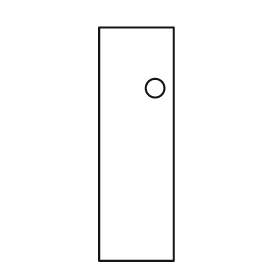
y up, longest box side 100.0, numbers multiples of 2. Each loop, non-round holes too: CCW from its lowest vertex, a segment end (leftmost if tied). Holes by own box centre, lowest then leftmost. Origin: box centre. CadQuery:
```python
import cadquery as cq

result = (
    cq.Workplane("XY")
    .moveTo(-16.0, -50.0)
    .lineTo(16.0, -50.0)
    .lineTo(16.0, 50.0)
    .lineTo(-16.0, 50.0)
    .close()
    .moveTo(8.0, 24.0)
    .circle(4.0)
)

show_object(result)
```